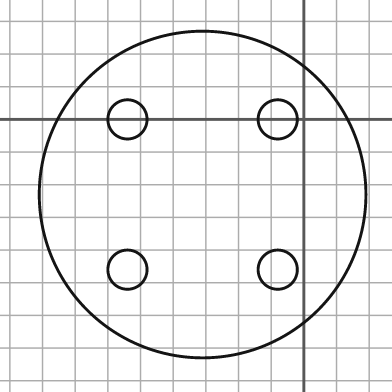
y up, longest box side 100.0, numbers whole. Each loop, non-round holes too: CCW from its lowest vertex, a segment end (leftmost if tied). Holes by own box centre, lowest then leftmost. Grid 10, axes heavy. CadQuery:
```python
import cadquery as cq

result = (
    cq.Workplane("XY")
    .moveTo(-31.0, -23.0)
    .circle(50.0)
    .moveTo(-54.0, -46.0)
    .circle(6.0)
    .moveTo(-8.0, -46.0)
    .circle(6.0)
    .moveTo(-54.0, 0.0)
    .circle(6.0)
    .moveTo(-8.0, 0.0)
    .circle(6.0)
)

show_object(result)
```